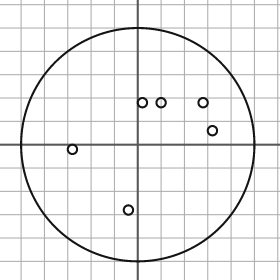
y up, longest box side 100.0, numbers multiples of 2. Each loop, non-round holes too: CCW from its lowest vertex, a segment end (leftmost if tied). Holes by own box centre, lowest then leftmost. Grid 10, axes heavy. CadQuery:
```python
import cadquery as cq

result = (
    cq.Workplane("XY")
    .moveTo(0.0, 0.0)
    .circle(50.0)
    .moveTo(-4.0, -28.0)
    .circle(2.0)
    .moveTo(-28.0, -2.0)
    .circle(2.0)
    .moveTo(32.0, 6.0)
    .circle(2.0)
    .moveTo(2.0, 18.0)
    .circle(2.0)
    .moveTo(10.0, 18.0)
    .circle(2.0)
    .moveTo(28.0, 18.0)
    .circle(2.0)
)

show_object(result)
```